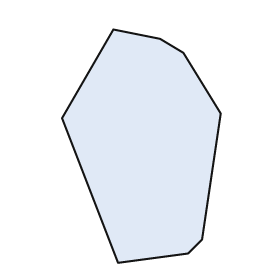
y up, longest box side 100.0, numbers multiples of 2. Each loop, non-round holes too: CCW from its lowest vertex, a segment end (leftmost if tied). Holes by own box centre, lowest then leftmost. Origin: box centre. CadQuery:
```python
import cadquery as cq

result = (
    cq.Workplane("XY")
    .moveTo(-10.0, -50.0)
    .lineTo(20.0, -46.0)
    .lineTo(26.0, -40.0)
    .lineTo(34.0, 14.0)
    .lineTo(18.0, 40.0)
    .lineTo(8.0, 46.0)
    .lineTo(-12.0, 50.0)
    .lineTo(-34.0, 12.0)
    .close()
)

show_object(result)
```